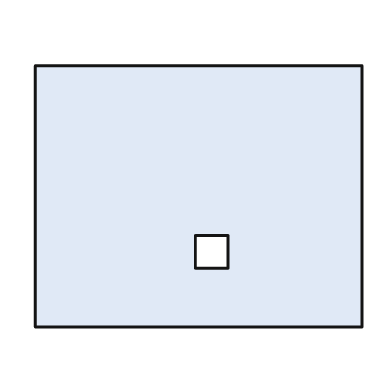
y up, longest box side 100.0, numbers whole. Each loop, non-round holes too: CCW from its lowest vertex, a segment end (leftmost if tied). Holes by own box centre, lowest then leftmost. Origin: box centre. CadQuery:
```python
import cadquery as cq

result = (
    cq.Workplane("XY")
    .moveTo(-50.0, -40.0)
    .lineTo(50.0, -40.0)
    .lineTo(50.0, 40.0)
    .lineTo(-50.0, 40.0)
    .close()
    .moveTo(-1.0, -22.0)
    .lineTo(9.0, -22.0)
    .lineTo(9.0, -12.0)
    .lineTo(-1.0, -12.0)
    .close()
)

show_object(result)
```